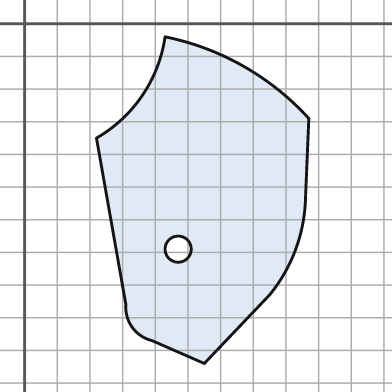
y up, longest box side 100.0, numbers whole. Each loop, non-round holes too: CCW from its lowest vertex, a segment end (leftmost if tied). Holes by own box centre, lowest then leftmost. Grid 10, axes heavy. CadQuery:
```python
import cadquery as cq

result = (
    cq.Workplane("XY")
    .moveTo(55.0, -104.0)
    .lineTo(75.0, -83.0)
    .threePointArc((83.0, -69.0), (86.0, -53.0))
    .lineTo(87.0, -29.0)
    .threePointArc((67.0, -13.0), (43.0, -4.0))
    .threePointArc((36.0, -22.0), (22.0, -35.0))
    .lineTo(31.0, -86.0)
    .threePointArc((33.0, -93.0), (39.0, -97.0))
    .close()
    .moveTo(47.0, -69.0)
    .circle(4.0)
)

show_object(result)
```